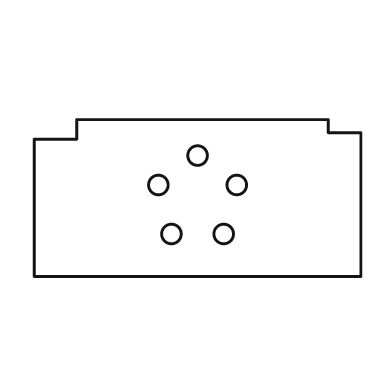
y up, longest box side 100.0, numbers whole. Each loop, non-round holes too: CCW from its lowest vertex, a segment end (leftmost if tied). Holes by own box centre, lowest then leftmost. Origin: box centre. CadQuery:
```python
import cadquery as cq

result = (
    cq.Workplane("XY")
    .moveTo(-50.0, -24.0)
    .lineTo(50.0, -24.0)
    .lineTo(50.0, 20.0)
    .lineTo(40.0, 20.0)
    .lineTo(40.0, 24.0)
    .lineTo(-37.0, 24.0)
    .lineTo(-37.0, 18.0)
    .lineTo(-50.0, 18.0)
    .close()
    .moveTo(-8.0, -11.0)
    .circle(3.0)
    .moveTo(8.0, -11.0)
    .circle(3.0)
    .moveTo(-12.0, 4.0)
    .circle(3.0)
    .moveTo(12.0, 4.0)
    .circle(3.0)
    .moveTo(0.0, 13.0)
    .circle(3.0)
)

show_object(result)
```